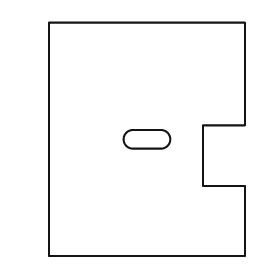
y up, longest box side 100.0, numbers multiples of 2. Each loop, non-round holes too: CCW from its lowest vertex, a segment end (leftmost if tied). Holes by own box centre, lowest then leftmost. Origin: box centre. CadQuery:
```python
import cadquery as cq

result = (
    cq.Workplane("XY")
    .moveTo(-42.0, -50.0)
    .lineTo(42.0, -50.0)
    .lineTo(42.0, -20.0)
    .lineTo(24.0, -20.0)
    .lineTo(24.0, 6.0)
    .lineTo(42.0, 6.0)
    .lineTo(42.0, 50.0)
    .lineTo(-42.0, 50.0)
    .close()
    .moveTo(-6.0, -4.0)
    .lineTo(6.0, -4.0)
    .threePointArc((10.0, 0.0), (6.0, 4.0))
    .lineTo(-6.0, 4.0)
    .threePointArc((-10.0, 0.0), (-6.0, -4.0))
    .close()
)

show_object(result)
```